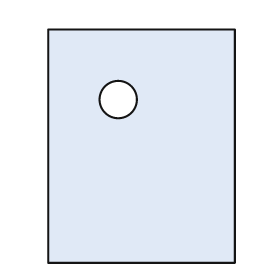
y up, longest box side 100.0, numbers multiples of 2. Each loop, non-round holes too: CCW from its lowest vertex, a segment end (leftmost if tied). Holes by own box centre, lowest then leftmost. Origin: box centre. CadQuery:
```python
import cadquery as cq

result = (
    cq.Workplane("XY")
    .moveTo(-40.0, -50.0)
    .lineTo(40.0, -50.0)
    .lineTo(40.0, 50.0)
    .lineTo(-40.0, 50.0)
    .close()
    .moveTo(-10.0, 20.0)
    .circle(8.0)
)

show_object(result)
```